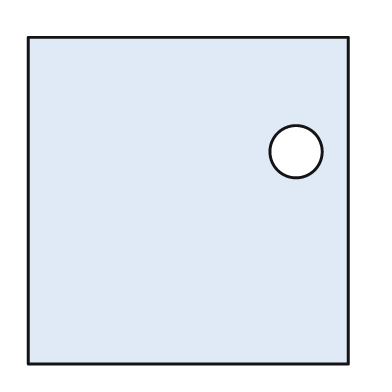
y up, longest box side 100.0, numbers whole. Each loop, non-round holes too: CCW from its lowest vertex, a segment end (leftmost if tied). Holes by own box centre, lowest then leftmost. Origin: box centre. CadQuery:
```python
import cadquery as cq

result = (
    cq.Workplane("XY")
    .moveTo(-49.0, -50.0)
    .lineTo(49.0, -50.0)
    .lineTo(49.0, 50.0)
    .lineTo(-49.0, 50.0)
    .close()
    .moveTo(33.0, 15.0)
    .circle(8.0)
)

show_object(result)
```